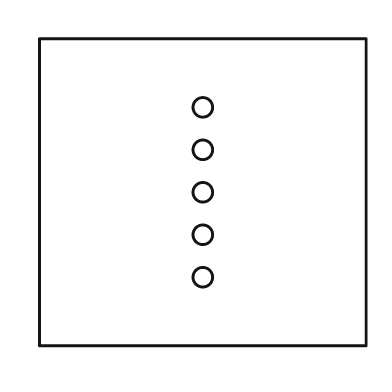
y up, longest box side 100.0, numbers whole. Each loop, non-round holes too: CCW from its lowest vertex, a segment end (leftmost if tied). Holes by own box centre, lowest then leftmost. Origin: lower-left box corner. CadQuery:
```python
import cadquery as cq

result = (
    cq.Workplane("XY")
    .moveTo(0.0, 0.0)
    .lineTo(100.0, 0.0)
    .lineTo(100.0, 94.0)
    .lineTo(0.0, 94.0)
    .close()
    .moveTo(50.0, 21.0)
    .circle(3.0)
    .moveTo(50.0, 34.0)
    .circle(3.0)
    .moveTo(50.0, 47.0)
    .circle(3.0)
    .moveTo(50.0, 60.0)
    .circle(3.0)
    .moveTo(50.0, 73.0)
    .circle(3.0)
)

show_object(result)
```